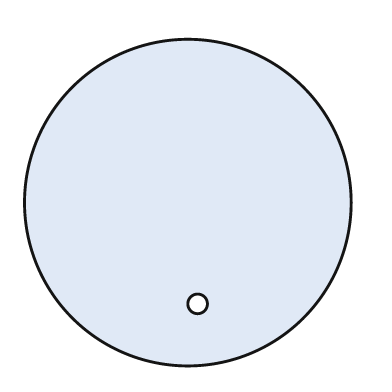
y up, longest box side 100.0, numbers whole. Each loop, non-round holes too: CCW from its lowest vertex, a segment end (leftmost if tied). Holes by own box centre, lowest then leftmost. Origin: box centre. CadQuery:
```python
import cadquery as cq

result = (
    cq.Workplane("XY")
    .moveTo(0.0, 0.0)
    .circle(50.0)
    .moveTo(3.0, -31.0)
    .circle(3.0)
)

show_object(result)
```